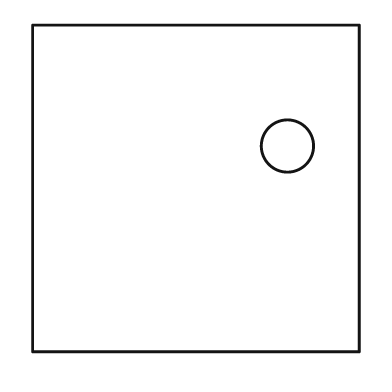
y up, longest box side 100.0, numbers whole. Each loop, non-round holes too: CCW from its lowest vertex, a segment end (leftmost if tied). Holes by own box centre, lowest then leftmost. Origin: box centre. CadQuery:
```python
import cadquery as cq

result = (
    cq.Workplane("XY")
    .moveTo(-50.0, -50.0)
    .lineTo(50.0, -50.0)
    .lineTo(50.0, 50.0)
    .lineTo(-50.0, 50.0)
    .close()
    .moveTo(28.0, 13.0)
    .circle(8.0)
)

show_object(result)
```